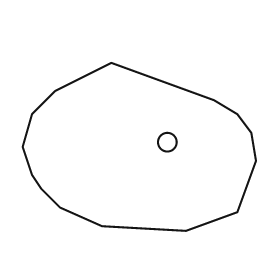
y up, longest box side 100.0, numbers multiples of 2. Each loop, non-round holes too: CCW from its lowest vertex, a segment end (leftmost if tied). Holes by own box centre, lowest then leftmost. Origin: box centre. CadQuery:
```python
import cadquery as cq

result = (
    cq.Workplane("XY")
    .moveTo(20.0, -36.0)
    .lineTo(42.0, -28.0)
    .lineTo(50.0, -6.0)
    .lineTo(48.0, 6.0)
    .lineTo(42.0, 14.0)
    .lineTo(32.0, 20.0)
    .lineTo(-12.0, 36.0)
    .lineTo(-36.0, 24.0)
    .lineTo(-46.0, 14.0)
    .lineTo(-50.0, 0.0)
    .lineTo(-46.0, -12.0)
    .lineTo(-42.0, -18.0)
    .lineTo(-34.0, -26.0)
    .lineTo(-16.0, -34.0)
    .close()
    .moveTo(12.0, 2.0)
    .circle(4.0)
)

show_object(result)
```